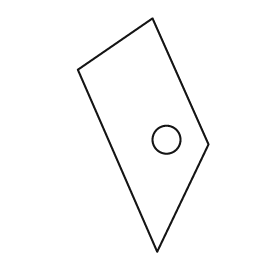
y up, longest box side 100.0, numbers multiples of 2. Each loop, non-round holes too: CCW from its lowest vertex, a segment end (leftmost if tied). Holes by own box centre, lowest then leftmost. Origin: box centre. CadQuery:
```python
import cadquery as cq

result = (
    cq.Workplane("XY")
    .moveTo(6.0, -50.0)
    .lineTo(28.0, -4.0)
    .lineTo(4.0, 50.0)
    .lineTo(-28.0, 28.0)
    .close()
    .moveTo(10.0, -2.0)
    .circle(6.0)
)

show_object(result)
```